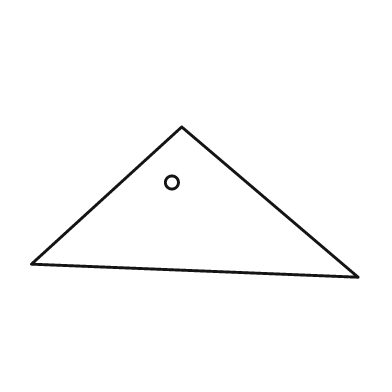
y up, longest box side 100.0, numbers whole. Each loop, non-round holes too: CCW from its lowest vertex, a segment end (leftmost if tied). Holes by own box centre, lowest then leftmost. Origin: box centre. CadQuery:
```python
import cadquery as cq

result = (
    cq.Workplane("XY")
    .moveTo(50.0, -23.0)
    .lineTo(-4.0, 23.0)
    .lineTo(-50.0, -19.0)
    .close()
    .moveTo(-7.0, 6.0)
    .circle(2.0)
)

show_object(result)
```